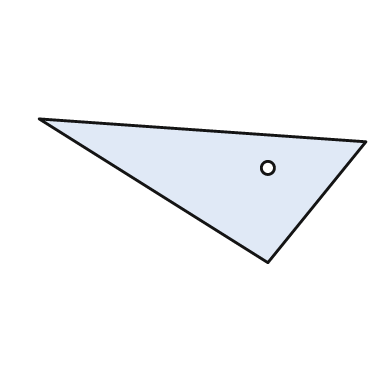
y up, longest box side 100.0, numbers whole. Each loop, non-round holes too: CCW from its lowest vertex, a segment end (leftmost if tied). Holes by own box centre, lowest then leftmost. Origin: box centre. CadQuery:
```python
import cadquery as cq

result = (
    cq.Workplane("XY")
    .moveTo(20.0, -22.0)
    .lineTo(50.0, 15.0)
    .lineTo(-50.0, 22.0)
    .close()
    .moveTo(20.0, 7.0)
    .circle(2.0)
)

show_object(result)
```